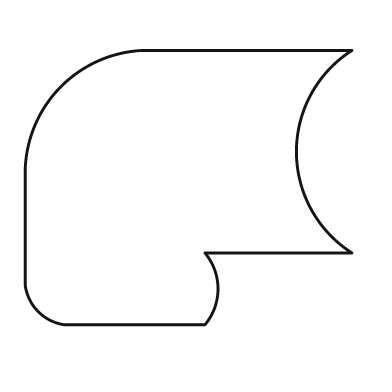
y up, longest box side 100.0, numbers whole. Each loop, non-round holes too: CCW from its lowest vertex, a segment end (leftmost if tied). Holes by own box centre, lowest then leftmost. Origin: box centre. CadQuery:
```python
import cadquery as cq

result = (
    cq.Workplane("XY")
    .moveTo(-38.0, -42.0)
    .lineTo(5.0, -42.0)
    .threePointArc((9.0, -31.0), (5.0, -20.0))
    .lineTo(50.0, -20.0)
    .threePointArc((33.0, 11.0), (50.0, 42.0))
    .lineTo(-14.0, 42.0)
    .threePointArc((-39.0, 31.0), (-50.0, 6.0))
    .lineTo(-50.0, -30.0)
    .threePointArc((-46.0, -38.0), (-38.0, -42.0))
    .close()
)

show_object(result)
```